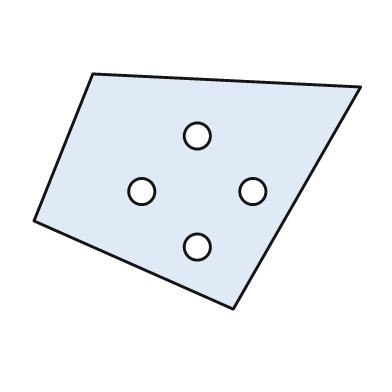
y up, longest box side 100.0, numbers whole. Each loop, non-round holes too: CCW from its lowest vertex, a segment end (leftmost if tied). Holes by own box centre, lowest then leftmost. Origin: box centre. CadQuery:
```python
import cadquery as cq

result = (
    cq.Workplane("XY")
    .moveTo(11.0, -36.0)
    .lineTo(50.0, 32.0)
    .lineTo(-32.0, 36.0)
    .lineTo(-50.0, -9.0)
    .close()
    .moveTo(0.0, -17.0)
    .circle(4.0)
    .moveTo(-17.0, 0.0)
    .circle(4.0)
    .moveTo(17.0, 0.0)
    .circle(4.0)
    .moveTo(0.0, 17.0)
    .circle(4.0)
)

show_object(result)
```